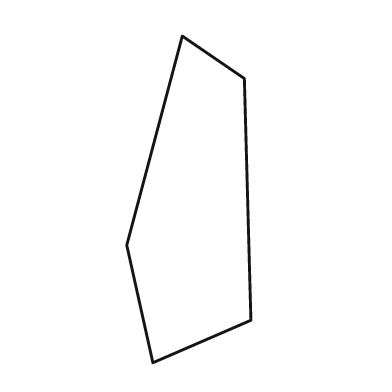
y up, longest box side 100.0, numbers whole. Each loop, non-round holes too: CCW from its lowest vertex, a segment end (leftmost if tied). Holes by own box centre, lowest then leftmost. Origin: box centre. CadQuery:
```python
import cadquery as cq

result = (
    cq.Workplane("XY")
    .moveTo(-11.0, -50.0)
    .lineTo(19.0, -37.0)
    .lineTo(17.0, 37.0)
    .lineTo(-2.0, 50.0)
    .lineTo(-19.0, -14.0)
    .close()
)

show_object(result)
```